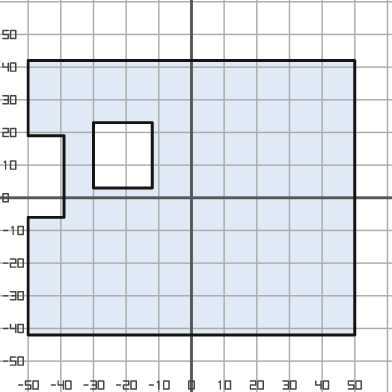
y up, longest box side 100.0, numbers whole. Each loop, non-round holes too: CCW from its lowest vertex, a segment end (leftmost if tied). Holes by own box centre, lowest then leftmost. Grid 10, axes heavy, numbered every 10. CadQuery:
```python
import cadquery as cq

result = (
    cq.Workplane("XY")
    .moveTo(-50.0, -42.0)
    .lineTo(50.0, -42.0)
    .lineTo(50.0, 42.0)
    .lineTo(-50.0, 42.0)
    .lineTo(-50.0, 19.0)
    .lineTo(-39.0, 19.0)
    .lineTo(-39.0, -6.0)
    .lineTo(-50.0, -6.0)
    .close()
    .moveTo(-30.0, 3.0)
    .lineTo(-12.0, 3.0)
    .lineTo(-12.0, 23.0)
    .lineTo(-30.0, 23.0)
    .close()
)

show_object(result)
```